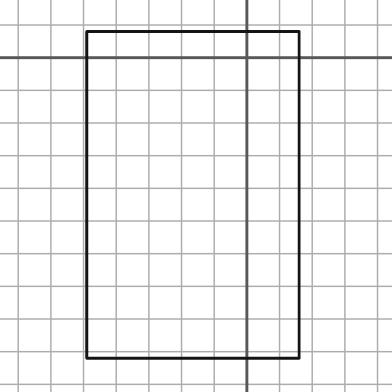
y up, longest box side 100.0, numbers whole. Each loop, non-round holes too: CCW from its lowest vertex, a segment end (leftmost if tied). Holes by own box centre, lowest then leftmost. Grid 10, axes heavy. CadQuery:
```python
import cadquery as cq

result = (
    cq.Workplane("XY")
    .moveTo(-49.0, -92.0)
    .lineTo(16.0, -92.0)
    .lineTo(16.0, 8.0)
    .lineTo(-49.0, 8.0)
    .close()
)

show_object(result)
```